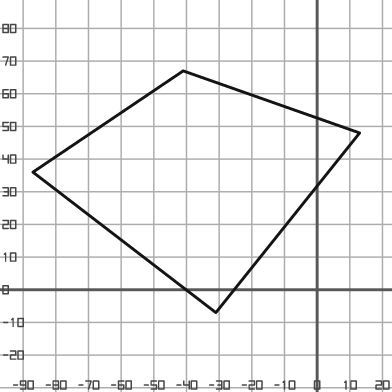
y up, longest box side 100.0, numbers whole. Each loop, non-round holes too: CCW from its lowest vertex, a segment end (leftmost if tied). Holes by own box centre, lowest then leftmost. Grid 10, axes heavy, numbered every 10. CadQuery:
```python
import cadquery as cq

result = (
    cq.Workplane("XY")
    .moveTo(-31.0, -7.0)
    .lineTo(13.0, 48.0)
    .lineTo(-41.0, 67.0)
    .lineTo(-87.0, 36.0)
    .close()
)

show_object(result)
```